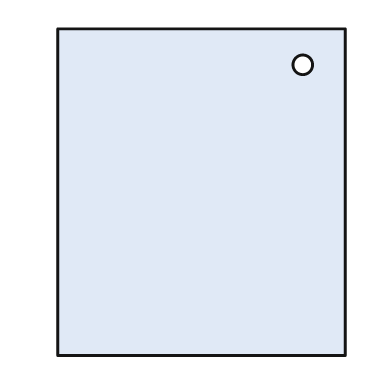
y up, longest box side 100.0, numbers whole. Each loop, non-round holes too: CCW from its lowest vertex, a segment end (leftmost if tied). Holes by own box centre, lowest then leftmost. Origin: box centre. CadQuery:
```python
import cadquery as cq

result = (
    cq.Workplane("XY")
    .moveTo(-44.0, -50.0)
    .lineTo(44.0, -50.0)
    .lineTo(44.0, 50.0)
    .lineTo(-44.0, 50.0)
    .close()
    .moveTo(31.0, 39.0)
    .circle(3.0)
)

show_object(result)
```